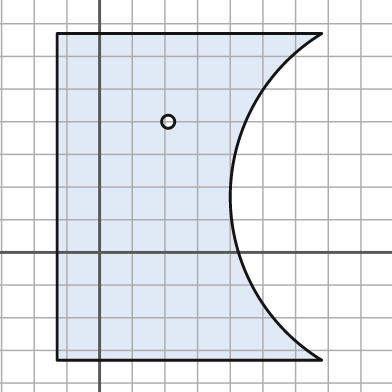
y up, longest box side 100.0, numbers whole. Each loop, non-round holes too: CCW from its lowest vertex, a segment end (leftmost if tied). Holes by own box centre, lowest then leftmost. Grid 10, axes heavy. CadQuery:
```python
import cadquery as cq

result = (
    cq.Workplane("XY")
    .moveTo(-13.0, -33.0)
    .lineTo(68.0, -33.0)
    .threePointArc((40.0, 17.0), (68.0, 67.0))
    .lineTo(-13.0, 67.0)
    .close()
    .moveTo(21.0, 40.0)
    .circle(2.0)
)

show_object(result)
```